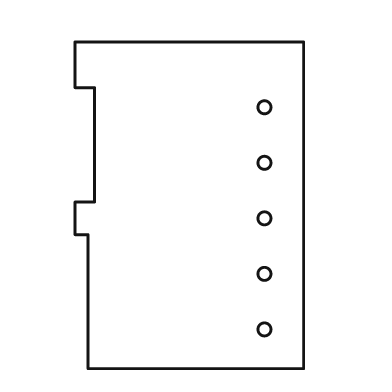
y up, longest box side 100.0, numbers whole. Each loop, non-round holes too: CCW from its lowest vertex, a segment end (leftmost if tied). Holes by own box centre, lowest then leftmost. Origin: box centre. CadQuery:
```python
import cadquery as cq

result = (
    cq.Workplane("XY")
    .moveTo(-31.0, -50.0)
    .lineTo(35.0, -50.0)
    .lineTo(35.0, 50.0)
    .lineTo(-35.0, 50.0)
    .lineTo(-35.0, 36.0)
    .lineTo(-29.0, 36.0)
    .lineTo(-29.0, 1.0)
    .lineTo(-35.0, 1.0)
    .lineTo(-35.0, -9.0)
    .lineTo(-31.0, -9.0)
    .close()
    .moveTo(23.0, -38.0)
    .circle(2.0)
    .moveTo(23.0, -21.0)
    .circle(2.0)
    .moveTo(23.0, -4.0)
    .circle(2.0)
    .moveTo(23.0, 13.0)
    .circle(2.0)
    .moveTo(23.0, 30.0)
    .circle(2.0)
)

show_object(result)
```